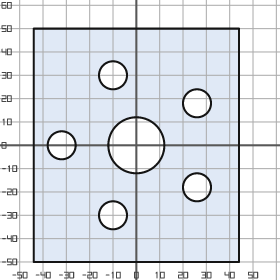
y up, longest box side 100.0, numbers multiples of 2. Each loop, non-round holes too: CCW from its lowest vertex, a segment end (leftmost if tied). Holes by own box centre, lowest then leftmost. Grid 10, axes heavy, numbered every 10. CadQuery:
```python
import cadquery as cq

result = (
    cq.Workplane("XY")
    .moveTo(-44.0, -50.0)
    .lineTo(44.0, -50.0)
    .lineTo(44.0, 50.0)
    .lineTo(-44.0, 50.0)
    .close()
    .moveTo(-10.0, -30.0)
    .circle(6.0)
    .moveTo(26.0, -18.0)
    .circle(6.0)
    .moveTo(-32.0, 0.0)
    .circle(6.0)
    .moveTo(0.0, 0.0)
    .circle(12.0)
    .moveTo(26.0, 18.0)
    .circle(6.0)
    .moveTo(-10.0, 30.0)
    .circle(6.0)
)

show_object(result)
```